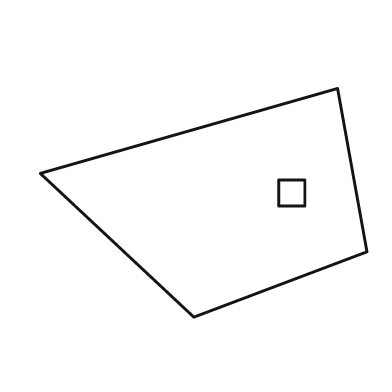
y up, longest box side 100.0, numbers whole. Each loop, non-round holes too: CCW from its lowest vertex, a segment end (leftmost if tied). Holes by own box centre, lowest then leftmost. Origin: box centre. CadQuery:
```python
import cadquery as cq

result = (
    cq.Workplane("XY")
    .moveTo(-3.0, -35.0)
    .lineTo(50.0, -15.0)
    .lineTo(41.0, 35.0)
    .lineTo(-50.0, 9.0)
    .close()
    .moveTo(23.0, -1.0)
    .lineTo(31.0, -1.0)
    .lineTo(31.0, 7.0)
    .lineTo(23.0, 7.0)
    .close()
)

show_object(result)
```